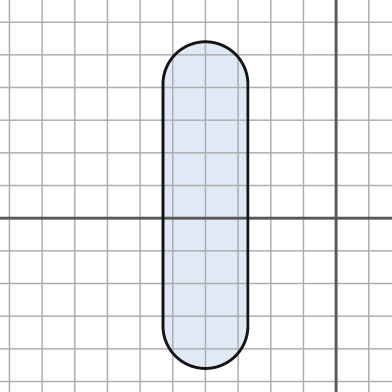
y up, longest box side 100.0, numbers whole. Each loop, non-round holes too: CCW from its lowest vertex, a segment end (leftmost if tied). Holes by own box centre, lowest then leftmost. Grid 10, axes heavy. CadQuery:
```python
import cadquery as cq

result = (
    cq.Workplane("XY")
    .moveTo(-53.0, -33.0)
    .threePointArc((-40.0, -46.0), (-27.0, -33.0))
    .lineTo(-27.0, 41.0)
    .threePointArc((-40.0, 54.0), (-53.0, 41.0))
    .close()
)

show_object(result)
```